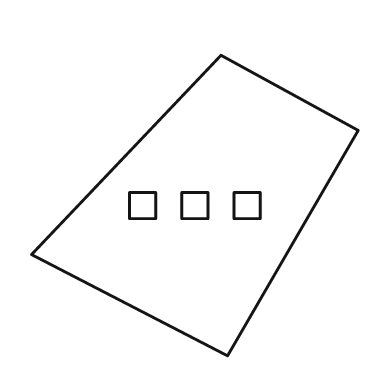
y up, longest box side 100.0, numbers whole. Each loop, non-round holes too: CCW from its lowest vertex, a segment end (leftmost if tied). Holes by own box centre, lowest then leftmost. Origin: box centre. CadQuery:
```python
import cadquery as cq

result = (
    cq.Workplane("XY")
    .moveTo(10.0, -46.0)
    .lineTo(50.0, 23.0)
    .lineTo(8.0, 46.0)
    .lineTo(-50.0, -15.0)
    .close()
    .moveTo(-20.0, -4.0)
    .lineTo(-12.0, -4.0)
    .lineTo(-12.0, 4.0)
    .lineTo(-20.0, 4.0)
    .close()
    .moveTo(-4.0, -4.0)
    .lineTo(4.0, -4.0)
    .lineTo(4.0, 4.0)
    .lineTo(-4.0, 4.0)
    .close()
    .moveTo(12.0, -4.0)
    .lineTo(20.0, -4.0)
    .lineTo(20.0, 4.0)
    .lineTo(12.0, 4.0)
    .close()
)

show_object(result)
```